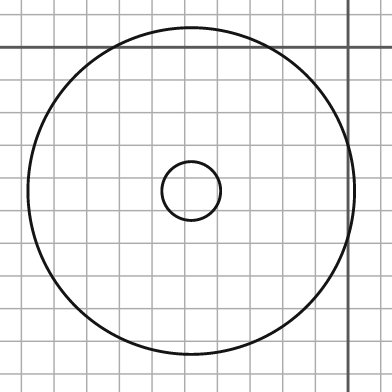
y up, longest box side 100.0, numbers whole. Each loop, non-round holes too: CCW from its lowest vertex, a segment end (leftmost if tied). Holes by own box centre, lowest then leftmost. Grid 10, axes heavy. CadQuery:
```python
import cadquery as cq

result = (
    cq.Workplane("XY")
    .moveTo(-48.0, -44.0)
    .circle(50.0)
    .moveTo(-48.0, -44.0)
    .circle(9.0)
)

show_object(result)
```